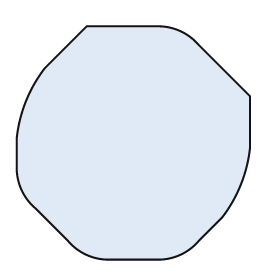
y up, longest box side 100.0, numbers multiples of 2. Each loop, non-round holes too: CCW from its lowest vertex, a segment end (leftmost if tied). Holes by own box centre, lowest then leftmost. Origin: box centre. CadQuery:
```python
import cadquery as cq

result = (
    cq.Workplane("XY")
    .moveTo(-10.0, -50.0)
    .lineTo(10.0, -50.0)
    .threePointArc((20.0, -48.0), (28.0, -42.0))
    .lineTo(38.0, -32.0)
    .threePointArc((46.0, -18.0), (50.0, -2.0))
    .lineTo(50.0, 20.0)
    .lineTo(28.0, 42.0)
    .threePointArc((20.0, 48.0), (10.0, 50.0))
    .lineTo(-20.0, 50.0)
    .lineTo(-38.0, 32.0)
    .threePointArc((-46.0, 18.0), (-50.0, 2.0))
    .lineTo(-50.0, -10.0)
    .threePointArc((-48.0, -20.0), (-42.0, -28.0))
    .lineTo(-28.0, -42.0)
    .threePointArc((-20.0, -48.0), (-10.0, -50.0))
    .close()
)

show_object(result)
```